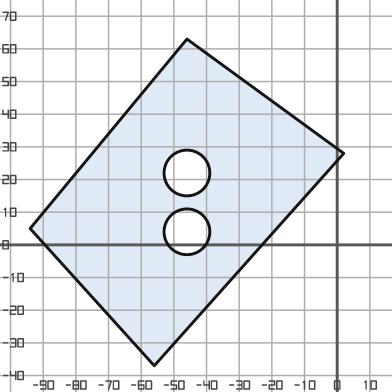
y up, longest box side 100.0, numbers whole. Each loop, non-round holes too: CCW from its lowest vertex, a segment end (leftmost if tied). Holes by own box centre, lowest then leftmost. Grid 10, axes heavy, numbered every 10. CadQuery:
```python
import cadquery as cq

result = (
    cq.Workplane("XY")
    .moveTo(-56.0, -37.0)
    .lineTo(2.0, 28.0)
    .lineTo(-46.0, 63.0)
    .lineTo(-94.0, 5.0)
    .close()
    .moveTo(-46.0, 4.0)
    .circle(7.0)
    .moveTo(-46.0, 22.0)
    .circle(7.0)
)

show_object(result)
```